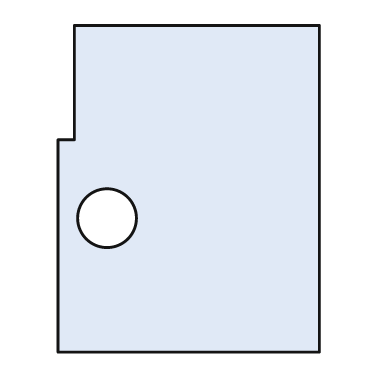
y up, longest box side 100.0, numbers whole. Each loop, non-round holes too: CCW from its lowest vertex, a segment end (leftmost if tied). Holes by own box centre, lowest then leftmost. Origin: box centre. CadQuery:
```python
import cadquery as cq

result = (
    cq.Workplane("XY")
    .moveTo(-40.0, -50.0)
    .lineTo(40.0, -50.0)
    .lineTo(40.0, 50.0)
    .lineTo(-35.0, 50.0)
    .lineTo(-35.0, 15.0)
    .lineTo(-40.0, 15.0)
    .close()
    .moveTo(-25.0, -9.0)
    .circle(9.0)
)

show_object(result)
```